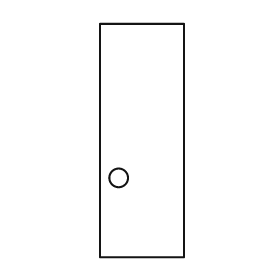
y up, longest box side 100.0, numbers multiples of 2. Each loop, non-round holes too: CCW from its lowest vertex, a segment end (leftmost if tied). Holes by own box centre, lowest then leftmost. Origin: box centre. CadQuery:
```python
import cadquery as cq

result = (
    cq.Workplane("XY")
    .moveTo(-18.0, -50.0)
    .lineTo(18.0, -50.0)
    .lineTo(18.0, 50.0)
    .lineTo(-18.0, 50.0)
    .close()
    .moveTo(-10.0, -16.0)
    .circle(4.0)
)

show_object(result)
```